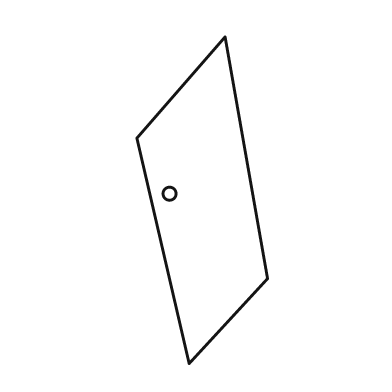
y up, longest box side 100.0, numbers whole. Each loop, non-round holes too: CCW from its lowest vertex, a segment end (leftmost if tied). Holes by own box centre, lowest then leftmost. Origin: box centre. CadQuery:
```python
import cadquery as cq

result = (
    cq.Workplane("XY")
    .moveTo(-4.0, -50.0)
    .lineTo(20.0, -24.0)
    .lineTo(7.0, 50.0)
    .lineTo(-20.0, 19.0)
    .close()
    .moveTo(-10.0, 2.0)
    .circle(2.0)
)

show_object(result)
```